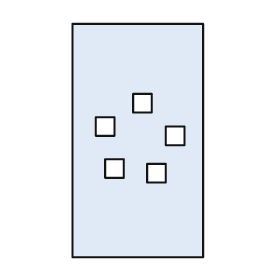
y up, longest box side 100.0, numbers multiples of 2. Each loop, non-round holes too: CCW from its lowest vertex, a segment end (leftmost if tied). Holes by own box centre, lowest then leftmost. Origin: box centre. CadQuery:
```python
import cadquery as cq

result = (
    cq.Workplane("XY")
    .moveTo(-28.0, -50.0)
    .lineTo(28.0, -50.0)
    .lineTo(28.0, 50.0)
    .lineTo(-28.0, 50.0)
    .close()
    .moveTo(4.0, -18.0)
    .lineTo(12.0, -18.0)
    .lineTo(12.0, -10.0)
    .lineTo(4.0, -10.0)
    .close()
    .moveTo(-14.0, -16.0)
    .lineTo(-6.0, -16.0)
    .lineTo(-6.0, -8.0)
    .lineTo(-14.0, -8.0)
    .close()
    .moveTo(12.0, -2.0)
    .lineTo(20.0, -2.0)
    .lineTo(20.0, 6.0)
    .lineTo(12.0, 6.0)
    .close()
    .moveTo(-18.0, 2.0)
    .lineTo(-10.0, 2.0)
    .lineTo(-10.0, 10.0)
    .lineTo(-18.0, 10.0)
    .close()
    .moveTo(-2.0, 12.0)
    .lineTo(6.0, 12.0)
    .lineTo(6.0, 20.0)
    .lineTo(-2.0, 20.0)
    .close()
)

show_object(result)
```